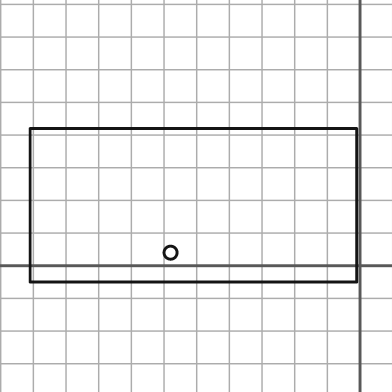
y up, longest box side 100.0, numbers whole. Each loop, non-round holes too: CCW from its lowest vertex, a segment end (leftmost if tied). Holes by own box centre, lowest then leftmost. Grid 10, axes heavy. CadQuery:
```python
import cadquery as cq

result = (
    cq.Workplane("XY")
    .moveTo(-101.0, -5.0)
    .lineTo(-1.0, -5.0)
    .lineTo(-1.0, 42.0)
    .lineTo(-101.0, 42.0)
    .close()
    .moveTo(-58.0, 4.0)
    .circle(2.0)
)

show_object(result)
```